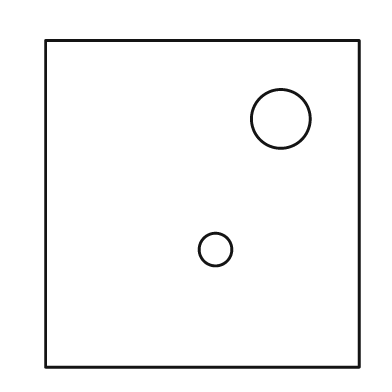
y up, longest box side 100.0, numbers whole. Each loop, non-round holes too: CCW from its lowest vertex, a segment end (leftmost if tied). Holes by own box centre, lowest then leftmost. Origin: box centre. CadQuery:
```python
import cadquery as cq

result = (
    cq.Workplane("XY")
    .moveTo(-48.0, -50.0)
    .lineTo(48.0, -50.0)
    .lineTo(48.0, 50.0)
    .lineTo(-48.0, 50.0)
    .close()
    .moveTo(4.0, -14.0)
    .circle(5.0)
    .moveTo(24.0, 26.0)
    .circle(9.0)
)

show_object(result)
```